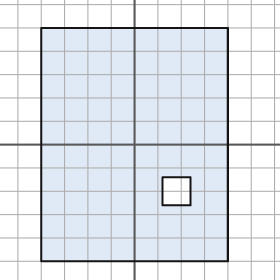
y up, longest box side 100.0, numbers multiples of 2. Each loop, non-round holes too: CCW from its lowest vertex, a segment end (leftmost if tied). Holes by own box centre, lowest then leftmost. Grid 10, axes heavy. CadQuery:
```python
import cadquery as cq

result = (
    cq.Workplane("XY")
    .moveTo(-40.0, -50.0)
    .lineTo(40.0, -50.0)
    .lineTo(40.0, 50.0)
    .lineTo(-40.0, 50.0)
    .close()
    .moveTo(12.0, -26.0)
    .lineTo(24.0, -26.0)
    .lineTo(24.0, -14.0)
    .lineTo(12.0, -14.0)
    .close()
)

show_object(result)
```